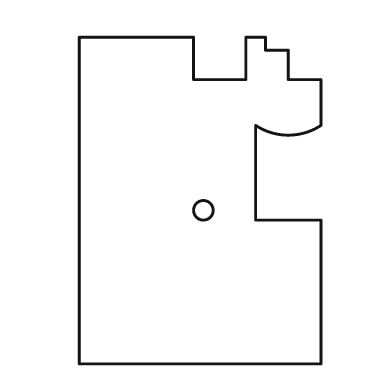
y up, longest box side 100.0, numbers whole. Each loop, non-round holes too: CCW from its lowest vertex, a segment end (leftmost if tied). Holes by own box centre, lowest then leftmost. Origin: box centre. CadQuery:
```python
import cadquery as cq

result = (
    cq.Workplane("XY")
    .moveTo(-37.0, -50.0)
    .lineTo(37.0, -50.0)
    .lineTo(37.0, -6.0)
    .lineTo(17.0, -6.0)
    .lineTo(17.0, 23.0)
    .threePointArc((27.0, 20.0), (37.0, 23.0))
    .lineTo(37.0, 37.0)
    .lineTo(27.0, 37.0)
    .lineTo(27.0, 46.0)
    .lineTo(20.0, 46.0)
    .lineTo(20.0, 50.0)
    .lineTo(14.0, 50.0)
    .lineTo(14.0, 37.0)
    .lineTo(-2.0, 37.0)
    .lineTo(-2.0, 50.0)
    .lineTo(-37.0, 50.0)
    .close()
    .moveTo(1.0, -3.0)
    .circle(3.0)
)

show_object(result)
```